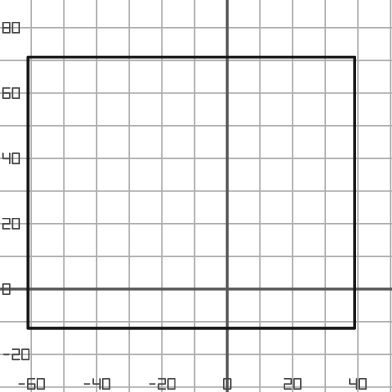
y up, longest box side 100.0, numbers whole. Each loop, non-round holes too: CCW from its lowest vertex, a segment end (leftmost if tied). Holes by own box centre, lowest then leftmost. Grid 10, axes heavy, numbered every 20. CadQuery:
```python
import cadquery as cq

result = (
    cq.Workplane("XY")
    .moveTo(-61.0, -12.0)
    .lineTo(39.0, -12.0)
    .lineTo(39.0, 71.0)
    .lineTo(-61.0, 71.0)
    .close()
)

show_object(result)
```